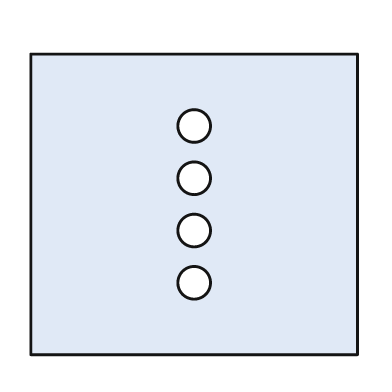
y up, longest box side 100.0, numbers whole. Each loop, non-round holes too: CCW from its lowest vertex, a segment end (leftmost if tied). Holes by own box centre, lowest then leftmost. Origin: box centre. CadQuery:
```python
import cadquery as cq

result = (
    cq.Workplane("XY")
    .moveTo(-50.0, -46.0)
    .lineTo(50.0, -46.0)
    .lineTo(50.0, 46.0)
    .lineTo(-50.0, 46.0)
    .close()
    .moveTo(0.0, -24.0)
    .circle(5.0)
    .moveTo(0.0, -8.0)
    .circle(5.0)
    .moveTo(0.0, 8.0)
    .circle(5.0)
    .moveTo(0.0, 24.0)
    .circle(5.0)
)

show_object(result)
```